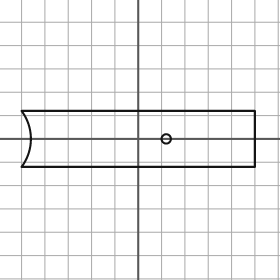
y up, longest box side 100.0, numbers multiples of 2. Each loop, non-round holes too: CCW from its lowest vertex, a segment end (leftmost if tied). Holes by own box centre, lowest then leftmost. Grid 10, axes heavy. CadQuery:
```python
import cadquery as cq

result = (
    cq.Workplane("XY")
    .moveTo(-50.0, -12.0)
    .lineTo(50.0, -12.0)
    .lineTo(50.0, 12.0)
    .lineTo(-50.0, 12.0)
    .threePointArc((-46.0, 0.0), (-50.0, -12.0))
    .close()
    .moveTo(12.0, 0.0)
    .circle(2.0)
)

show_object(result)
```